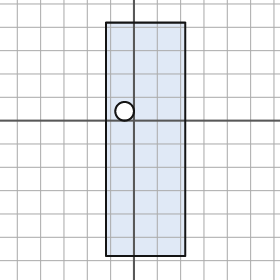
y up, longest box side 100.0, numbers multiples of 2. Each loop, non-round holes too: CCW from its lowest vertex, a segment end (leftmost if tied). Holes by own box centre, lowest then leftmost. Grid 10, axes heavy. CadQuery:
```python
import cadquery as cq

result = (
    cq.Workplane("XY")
    .moveTo(-12.0, -58.0)
    .lineTo(22.0, -58.0)
    .lineTo(22.0, 42.0)
    .lineTo(-12.0, 42.0)
    .close()
    .moveTo(-4.0, 4.0)
    .circle(4.0)
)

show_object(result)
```